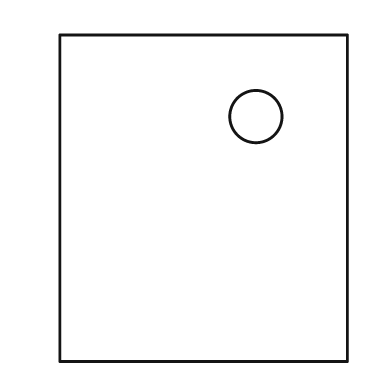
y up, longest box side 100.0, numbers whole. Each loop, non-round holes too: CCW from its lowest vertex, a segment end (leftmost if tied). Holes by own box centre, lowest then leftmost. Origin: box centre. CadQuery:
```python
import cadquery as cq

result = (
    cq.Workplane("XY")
    .moveTo(-44.0, -50.0)
    .lineTo(44.0, -50.0)
    .lineTo(44.0, 50.0)
    .lineTo(-44.0, 50.0)
    .close()
    .moveTo(16.0, 25.0)
    .circle(8.0)
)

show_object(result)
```